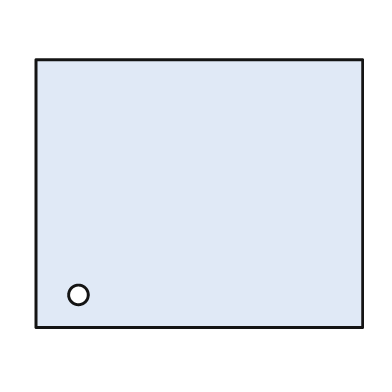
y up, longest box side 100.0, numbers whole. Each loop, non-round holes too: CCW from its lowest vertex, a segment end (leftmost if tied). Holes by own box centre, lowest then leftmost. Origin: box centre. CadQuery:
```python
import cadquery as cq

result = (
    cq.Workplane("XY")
    .moveTo(-50.0, -41.0)
    .lineTo(50.0, -41.0)
    .lineTo(50.0, 41.0)
    .lineTo(-50.0, 41.0)
    .close()
    .moveTo(-37.0, -31.0)
    .circle(3.0)
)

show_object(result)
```